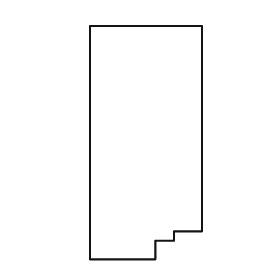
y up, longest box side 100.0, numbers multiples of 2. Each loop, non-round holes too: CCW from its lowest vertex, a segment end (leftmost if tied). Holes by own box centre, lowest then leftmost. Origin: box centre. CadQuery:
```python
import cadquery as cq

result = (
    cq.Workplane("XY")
    .moveTo(-24.0, -50.0)
    .lineTo(4.0, -50.0)
    .lineTo(4.0, -42.0)
    .lineTo(12.0, -42.0)
    .lineTo(12.0, -38.0)
    .lineTo(24.0, -38.0)
    .lineTo(24.0, 50.0)
    .lineTo(-24.0, 50.0)
    .close()
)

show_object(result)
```